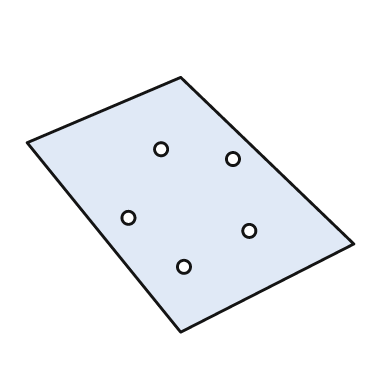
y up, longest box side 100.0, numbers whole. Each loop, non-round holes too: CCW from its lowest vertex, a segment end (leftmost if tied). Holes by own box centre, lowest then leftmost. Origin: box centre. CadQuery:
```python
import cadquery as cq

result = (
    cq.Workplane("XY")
    .moveTo(-3.0, -39.0)
    .lineTo(50.0, -12.0)
    .lineTo(-3.0, 39.0)
    .lineTo(-50.0, 19.0)
    .close()
    .moveTo(-2.0, -19.0)
    .circle(2.0)
    .moveTo(18.0, -8.0)
    .circle(2.0)
    .moveTo(-19.0, -4.0)
    .circle(2.0)
    .moveTo(13.0, 14.0)
    .circle(2.0)
    .moveTo(-9.0, 17.0)
    .circle(2.0)
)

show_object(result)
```